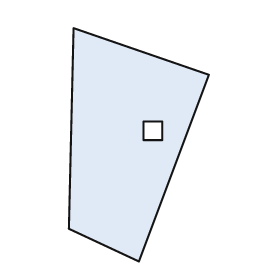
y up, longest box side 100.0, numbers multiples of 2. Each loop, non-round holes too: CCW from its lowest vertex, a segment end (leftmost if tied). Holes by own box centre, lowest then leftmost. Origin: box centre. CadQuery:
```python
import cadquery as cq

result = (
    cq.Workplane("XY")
    .moveTo(0.0, -50.0)
    .lineTo(30.0, 30.0)
    .lineTo(-28.0, 50.0)
    .lineTo(-30.0, -36.0)
    .close()
    .moveTo(2.0, 2.0)
    .lineTo(10.0, 2.0)
    .lineTo(10.0, 10.0)
    .lineTo(2.0, 10.0)
    .close()
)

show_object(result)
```